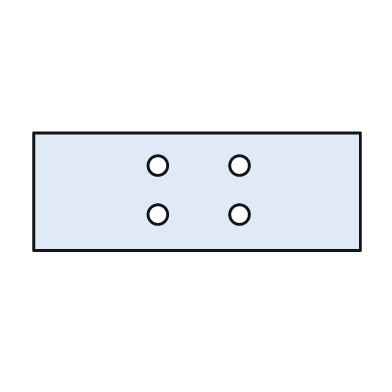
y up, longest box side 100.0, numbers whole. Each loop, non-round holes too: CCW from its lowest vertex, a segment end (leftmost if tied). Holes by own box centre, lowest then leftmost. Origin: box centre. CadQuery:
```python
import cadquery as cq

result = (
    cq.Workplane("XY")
    .moveTo(-50.0, -18.0)
    .lineTo(50.0, -18.0)
    .lineTo(50.0, 18.0)
    .lineTo(-50.0, 18.0)
    .close()
    .moveTo(-12.0, -7.0)
    .circle(3.0)
    .moveTo(13.0, -7.0)
    .circle(3.0)
    .moveTo(-12.0, 8.0)
    .circle(3.0)
    .moveTo(13.0, 8.0)
    .circle(3.0)
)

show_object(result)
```